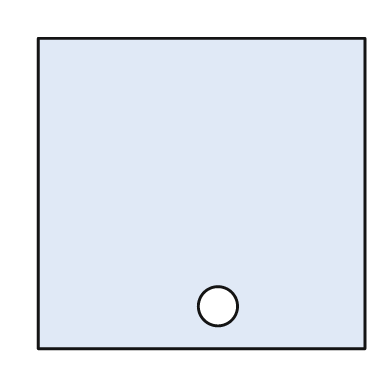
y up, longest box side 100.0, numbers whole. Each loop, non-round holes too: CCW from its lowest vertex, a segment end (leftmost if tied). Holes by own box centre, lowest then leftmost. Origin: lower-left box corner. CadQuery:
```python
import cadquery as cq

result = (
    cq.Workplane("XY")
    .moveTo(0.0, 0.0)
    .lineTo(100.0, 0.0)
    .lineTo(100.0, 95.0)
    .lineTo(0.0, 95.0)
    .close()
    .moveTo(55.0, 13.0)
    .circle(6.0)
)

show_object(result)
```